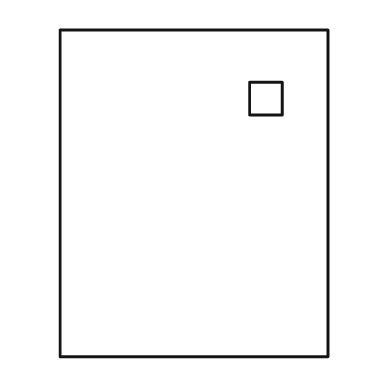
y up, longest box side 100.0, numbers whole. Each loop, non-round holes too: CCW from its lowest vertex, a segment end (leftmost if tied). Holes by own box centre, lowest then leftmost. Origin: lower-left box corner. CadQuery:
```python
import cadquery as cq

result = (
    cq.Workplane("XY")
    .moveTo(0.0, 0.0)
    .lineTo(82.0, 0.0)
    .lineTo(82.0, 100.0)
    .lineTo(0.0, 100.0)
    .close()
    .moveTo(58.0, 74.0)
    .lineTo(68.0, 74.0)
    .lineTo(68.0, 84.0)
    .lineTo(58.0, 84.0)
    .close()
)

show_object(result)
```